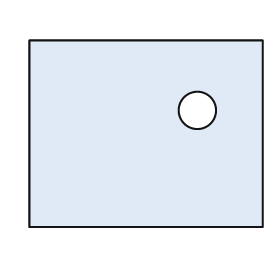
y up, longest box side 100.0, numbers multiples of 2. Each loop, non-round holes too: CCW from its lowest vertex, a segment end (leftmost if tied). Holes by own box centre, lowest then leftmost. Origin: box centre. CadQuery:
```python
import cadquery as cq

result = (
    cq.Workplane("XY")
    .moveTo(-50.0, -40.0)
    .lineTo(50.0, -40.0)
    .lineTo(50.0, 40.0)
    .lineTo(-50.0, 40.0)
    .close()
    .moveTo(22.0, 10.0)
    .circle(8.0)
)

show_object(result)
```